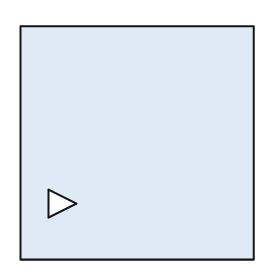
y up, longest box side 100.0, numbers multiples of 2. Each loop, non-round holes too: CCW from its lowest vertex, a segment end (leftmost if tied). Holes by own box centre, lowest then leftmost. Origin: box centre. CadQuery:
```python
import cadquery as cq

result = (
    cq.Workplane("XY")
    .moveTo(-50.0, -50.0)
    .lineTo(50.0, -50.0)
    .lineTo(50.0, 50.0)
    .lineTo(-50.0, 50.0)
    .close()
    .moveTo(-38.0, -32.0)
    .lineTo(-26.0, -26.0)
    .lineTo(-38.0, -20.0)
    .close()
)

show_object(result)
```